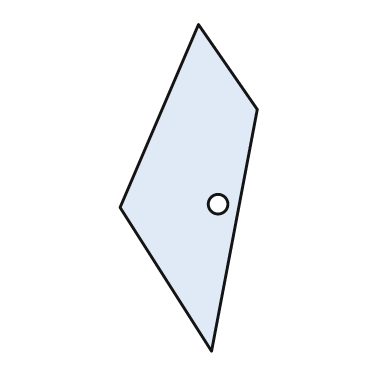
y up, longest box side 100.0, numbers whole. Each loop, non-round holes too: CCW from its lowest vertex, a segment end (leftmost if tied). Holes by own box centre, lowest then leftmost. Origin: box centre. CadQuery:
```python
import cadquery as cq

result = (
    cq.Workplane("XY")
    .moveTo(7.0, -50.0)
    .lineTo(21.0, 24.0)
    .lineTo(3.0, 50.0)
    .lineTo(-21.0, -6.0)
    .close()
    .moveTo(9.0, -5.0)
    .circle(3.0)
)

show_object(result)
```